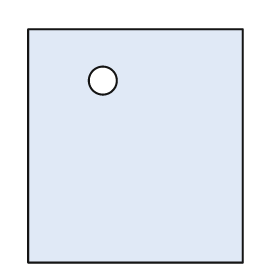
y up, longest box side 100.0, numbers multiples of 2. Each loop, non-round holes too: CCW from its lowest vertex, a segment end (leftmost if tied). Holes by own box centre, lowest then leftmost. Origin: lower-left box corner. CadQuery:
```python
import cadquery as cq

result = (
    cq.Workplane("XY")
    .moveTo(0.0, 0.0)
    .lineTo(92.0, 0.0)
    .lineTo(92.0, 100.0)
    .lineTo(0.0, 100.0)
    .close()
    .moveTo(32.0, 78.0)
    .circle(6.0)
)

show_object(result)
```